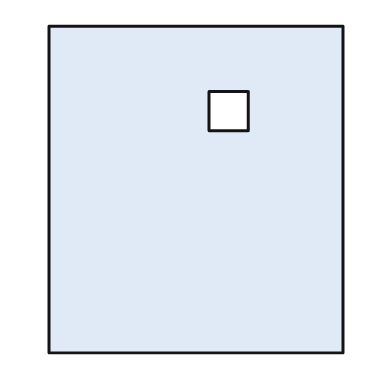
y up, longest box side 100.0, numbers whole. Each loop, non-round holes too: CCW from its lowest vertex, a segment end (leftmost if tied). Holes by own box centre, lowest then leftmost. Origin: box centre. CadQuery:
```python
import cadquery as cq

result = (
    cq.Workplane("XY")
    .moveTo(-45.0, -50.0)
    .lineTo(45.0, -50.0)
    .lineTo(45.0, 50.0)
    .lineTo(-45.0, 50.0)
    .close()
    .moveTo(4.0, 18.0)
    .lineTo(16.0, 18.0)
    .lineTo(16.0, 30.0)
    .lineTo(4.0, 30.0)
    .close()
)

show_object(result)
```